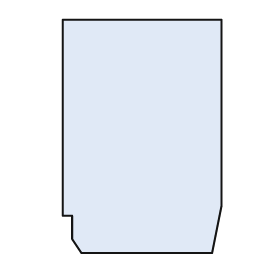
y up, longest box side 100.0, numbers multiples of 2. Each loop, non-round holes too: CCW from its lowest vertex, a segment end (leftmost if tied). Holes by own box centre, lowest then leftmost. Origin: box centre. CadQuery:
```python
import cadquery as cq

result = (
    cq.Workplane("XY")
    .moveTo(-26.0, -50.0)
    .lineTo(30.0, -50.0)
    .lineTo(34.0, -30.0)
    .lineTo(34.0, 50.0)
    .lineTo(-34.0, 50.0)
    .lineTo(-34.0, -34.0)
    .lineTo(-30.0, -34.0)
    .lineTo(-30.0, -44.0)
    .close()
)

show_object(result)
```